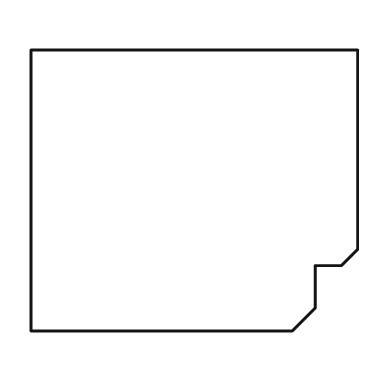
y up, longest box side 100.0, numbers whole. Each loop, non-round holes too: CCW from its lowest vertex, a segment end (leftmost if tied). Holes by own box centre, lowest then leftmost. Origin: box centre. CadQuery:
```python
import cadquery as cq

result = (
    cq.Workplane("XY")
    .moveTo(-50.0, -43.0)
    .lineTo(30.0, -43.0)
    .lineTo(37.0, -36.0)
    .lineTo(37.0, -23.0)
    .lineTo(45.0, -23.0)
    .lineTo(50.0, -18.0)
    .lineTo(50.0, 43.0)
    .lineTo(-50.0, 43.0)
    .close()
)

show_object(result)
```